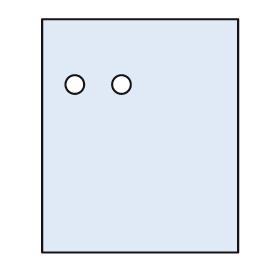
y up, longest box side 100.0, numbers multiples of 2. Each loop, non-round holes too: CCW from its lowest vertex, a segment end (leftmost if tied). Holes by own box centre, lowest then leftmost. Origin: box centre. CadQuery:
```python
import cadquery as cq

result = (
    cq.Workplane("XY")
    .moveTo(-42.0, -50.0)
    .lineTo(42.0, -50.0)
    .lineTo(42.0, 50.0)
    .lineTo(-42.0, 50.0)
    .close()
    .moveTo(-28.0, 22.0)
    .circle(4.0)
    .moveTo(-8.0, 22.0)
    .circle(4.0)
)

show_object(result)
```